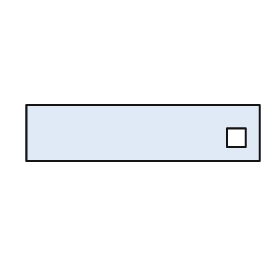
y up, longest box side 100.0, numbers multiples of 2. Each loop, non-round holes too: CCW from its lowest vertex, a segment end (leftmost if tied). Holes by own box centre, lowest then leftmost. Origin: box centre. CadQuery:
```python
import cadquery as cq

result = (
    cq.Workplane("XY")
    .moveTo(-50.0, -12.0)
    .lineTo(50.0, -12.0)
    .lineTo(50.0, 12.0)
    .lineTo(-50.0, 12.0)
    .close()
    .moveTo(36.0, -6.0)
    .lineTo(44.0, -6.0)
    .lineTo(44.0, 2.0)
    .lineTo(36.0, 2.0)
    .close()
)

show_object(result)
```